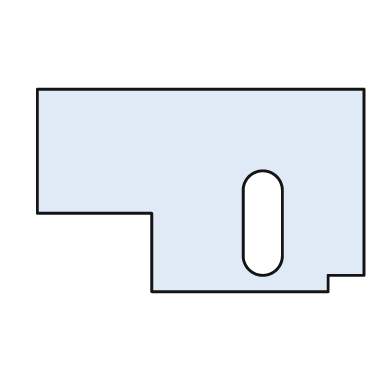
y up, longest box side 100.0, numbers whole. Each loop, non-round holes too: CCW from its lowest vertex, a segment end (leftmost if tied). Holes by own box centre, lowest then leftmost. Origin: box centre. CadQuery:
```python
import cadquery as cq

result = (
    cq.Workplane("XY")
    .moveTo(-15.0, -31.0)
    .lineTo(39.0, -31.0)
    .lineTo(39.0, -26.0)
    .lineTo(50.0, -26.0)
    .lineTo(50.0, 31.0)
    .lineTo(-50.0, 31.0)
    .lineTo(-50.0, -7.0)
    .lineTo(-15.0, -7.0)
    .close()
    .moveTo(13.0, -20.0)
    .threePointArc((19.0, -26.0), (25.0, -20.0))
    .lineTo(25.0, 0.0)
    .threePointArc((19.0, 6.0), (13.0, 0.0))
    .close()
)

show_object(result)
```